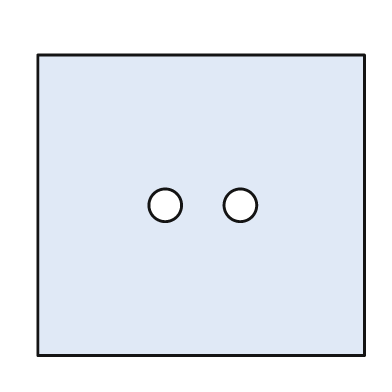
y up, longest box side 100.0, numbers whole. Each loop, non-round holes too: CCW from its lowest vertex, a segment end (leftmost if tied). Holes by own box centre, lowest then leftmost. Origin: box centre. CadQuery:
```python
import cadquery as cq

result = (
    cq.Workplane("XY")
    .moveTo(-50.0, -46.0)
    .lineTo(50.0, -46.0)
    .lineTo(50.0, 46.0)
    .lineTo(-50.0, 46.0)
    .close()
    .moveTo(-11.0, 0.0)
    .circle(5.0)
    .moveTo(12.0, 0.0)
    .circle(5.0)
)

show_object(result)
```